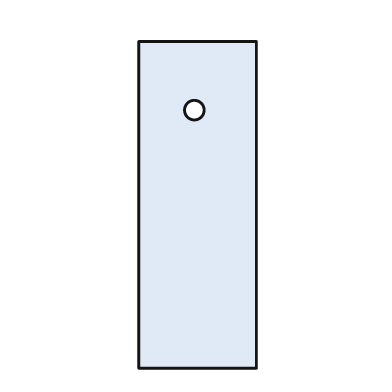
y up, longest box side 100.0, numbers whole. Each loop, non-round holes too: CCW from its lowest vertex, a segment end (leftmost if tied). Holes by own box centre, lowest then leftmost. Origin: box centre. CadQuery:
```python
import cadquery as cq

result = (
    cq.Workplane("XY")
    .moveTo(-18.0, -50.0)
    .lineTo(18.0, -50.0)
    .lineTo(18.0, 50.0)
    .lineTo(-18.0, 50.0)
    .close()
    .moveTo(-1.0, 29.0)
    .circle(3.0)
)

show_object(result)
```